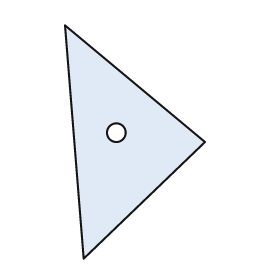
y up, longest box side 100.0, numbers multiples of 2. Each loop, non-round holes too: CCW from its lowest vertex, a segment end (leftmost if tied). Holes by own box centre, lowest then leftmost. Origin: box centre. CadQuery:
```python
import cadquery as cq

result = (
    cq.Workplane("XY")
    .moveTo(-22.0, -50.0)
    .lineTo(30.0, 0.0)
    .lineTo(-30.0, 50.0)
    .close()
    .moveTo(-8.0, 4.0)
    .circle(4.0)
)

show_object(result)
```